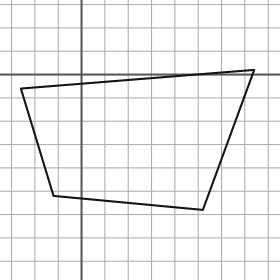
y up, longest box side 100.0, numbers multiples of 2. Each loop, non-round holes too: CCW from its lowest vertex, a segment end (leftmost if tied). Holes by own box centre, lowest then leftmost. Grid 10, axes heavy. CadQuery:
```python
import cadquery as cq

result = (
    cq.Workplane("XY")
    .moveTo(52.0, -58.0)
    .lineTo(74.0, 2.0)
    .lineTo(-26.0, -6.0)
    .lineTo(-12.0, -52.0)
    .close()
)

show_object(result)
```